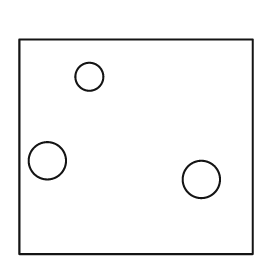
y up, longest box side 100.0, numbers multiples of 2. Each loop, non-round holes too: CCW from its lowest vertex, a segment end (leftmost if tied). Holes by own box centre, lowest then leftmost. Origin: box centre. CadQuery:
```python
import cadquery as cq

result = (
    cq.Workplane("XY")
    .moveTo(-50.0, -46.0)
    .lineTo(50.0, -46.0)
    .lineTo(50.0, 46.0)
    .lineTo(-50.0, 46.0)
    .close()
    .moveTo(28.0, -14.0)
    .circle(8.0)
    .moveTo(-38.0, -6.0)
    .circle(8.0)
    .moveTo(-20.0, 30.0)
    .circle(6.0)
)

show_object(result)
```